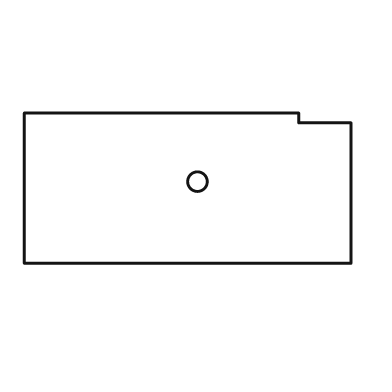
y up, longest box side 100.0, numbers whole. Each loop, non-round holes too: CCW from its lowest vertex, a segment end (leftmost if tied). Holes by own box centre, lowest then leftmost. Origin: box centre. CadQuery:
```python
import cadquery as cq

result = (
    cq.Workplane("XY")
    .moveTo(-50.0, -23.0)
    .lineTo(50.0, -23.0)
    .lineTo(50.0, 20.0)
    .lineTo(34.0, 20.0)
    .lineTo(34.0, 23.0)
    .lineTo(-50.0, 23.0)
    .close()
    .moveTo(3.0, 2.0)
    .circle(3.0)
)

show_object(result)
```